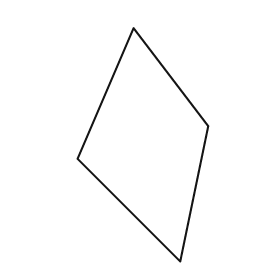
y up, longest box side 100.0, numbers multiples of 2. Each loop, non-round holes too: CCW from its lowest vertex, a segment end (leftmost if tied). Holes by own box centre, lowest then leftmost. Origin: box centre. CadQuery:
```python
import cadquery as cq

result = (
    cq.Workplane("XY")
    .moveTo(16.0, -50.0)
    .lineTo(28.0, 8.0)
    .lineTo(-4.0, 50.0)
    .lineTo(-28.0, -6.0)
    .close()
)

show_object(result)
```